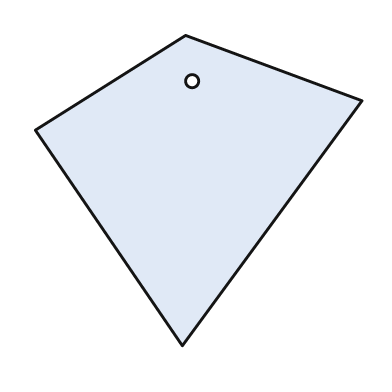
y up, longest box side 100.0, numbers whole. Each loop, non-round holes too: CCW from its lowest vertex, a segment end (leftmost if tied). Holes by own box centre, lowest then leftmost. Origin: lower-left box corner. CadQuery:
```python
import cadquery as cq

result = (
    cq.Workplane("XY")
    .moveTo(45.0, 0.0)
    .lineTo(100.0, 75.0)
    .lineTo(46.0, 95.0)
    .lineTo(0.0, 66.0)
    .close()
    .moveTo(48.0, 81.0)
    .circle(2.0)
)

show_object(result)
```